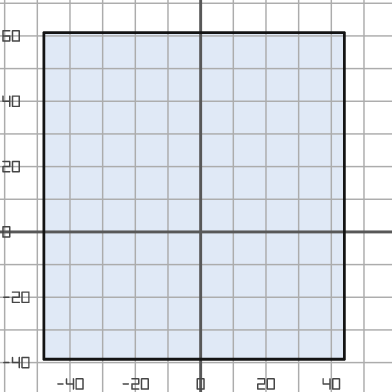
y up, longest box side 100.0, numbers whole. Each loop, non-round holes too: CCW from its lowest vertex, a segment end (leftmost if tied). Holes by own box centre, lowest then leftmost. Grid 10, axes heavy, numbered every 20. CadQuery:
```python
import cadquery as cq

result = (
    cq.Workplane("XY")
    .moveTo(-48.0, -39.0)
    .lineTo(44.0, -39.0)
    .lineTo(44.0, 61.0)
    .lineTo(-48.0, 61.0)
    .close()
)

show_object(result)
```